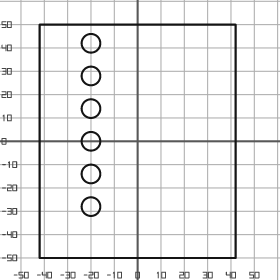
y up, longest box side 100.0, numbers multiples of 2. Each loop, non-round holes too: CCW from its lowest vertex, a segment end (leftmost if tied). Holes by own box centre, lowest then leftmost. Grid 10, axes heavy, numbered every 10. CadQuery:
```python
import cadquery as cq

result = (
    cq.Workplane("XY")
    .moveTo(-42.0, -50.0)
    .lineTo(42.0, -50.0)
    .lineTo(42.0, 50.0)
    .lineTo(-42.0, 50.0)
    .close()
    .moveTo(-20.0, -28.0)
    .circle(4.0)
    .moveTo(-20.0, -14.0)
    .circle(4.0)
    .moveTo(-20.0, 0.0)
    .circle(4.0)
    .moveTo(-20.0, 14.0)
    .circle(4.0)
    .moveTo(-20.0, 28.0)
    .circle(4.0)
    .moveTo(-20.0, 42.0)
    .circle(4.0)
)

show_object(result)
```